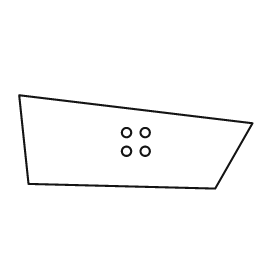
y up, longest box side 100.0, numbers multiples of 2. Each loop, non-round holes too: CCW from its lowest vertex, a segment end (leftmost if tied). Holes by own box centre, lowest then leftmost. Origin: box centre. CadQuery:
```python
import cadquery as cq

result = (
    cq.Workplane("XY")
    .moveTo(34.0, -20.0)
    .lineTo(50.0, 8.0)
    .lineTo(-50.0, 20.0)
    .lineTo(-46.0, -18.0)
    .close()
    .moveTo(-4.0, -4.0)
    .circle(2.0)
    .moveTo(4.0, -4.0)
    .circle(2.0)
    .moveTo(-4.0, 4.0)
    .circle(2.0)
    .moveTo(4.0, 4.0)
    .circle(2.0)
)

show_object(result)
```